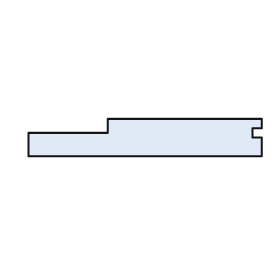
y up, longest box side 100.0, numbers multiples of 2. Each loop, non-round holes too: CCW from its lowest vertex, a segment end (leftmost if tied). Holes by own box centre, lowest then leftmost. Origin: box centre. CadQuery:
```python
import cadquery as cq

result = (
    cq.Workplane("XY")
    .moveTo(-50.0, -8.0)
    .lineTo(50.0, -8.0)
    .lineTo(50.0, 0.0)
    .lineTo(46.0, 0.0)
    .lineTo(46.0, 4.0)
    .lineTo(50.0, 4.0)
    .lineTo(50.0, 8.0)
    .lineTo(-16.0, 8.0)
    .lineTo(-16.0, 2.0)
    .lineTo(-50.0, 2.0)
    .close()
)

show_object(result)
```